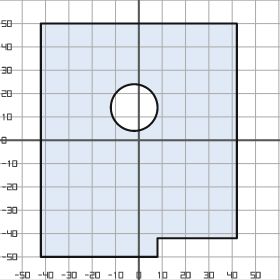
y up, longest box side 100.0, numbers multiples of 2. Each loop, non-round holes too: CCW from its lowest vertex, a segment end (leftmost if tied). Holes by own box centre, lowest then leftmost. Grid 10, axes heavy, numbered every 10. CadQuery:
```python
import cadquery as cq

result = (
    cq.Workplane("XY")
    .moveTo(-42.0, -50.0)
    .lineTo(8.0, -50.0)
    .lineTo(8.0, -42.0)
    .lineTo(42.0, -42.0)
    .lineTo(42.0, 50.0)
    .lineTo(-42.0, 50.0)
    .close()
    .moveTo(-2.0, 14.0)
    .circle(10.0)
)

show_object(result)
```